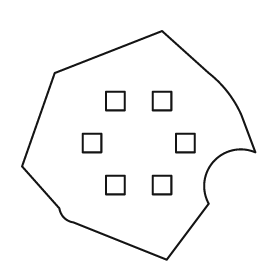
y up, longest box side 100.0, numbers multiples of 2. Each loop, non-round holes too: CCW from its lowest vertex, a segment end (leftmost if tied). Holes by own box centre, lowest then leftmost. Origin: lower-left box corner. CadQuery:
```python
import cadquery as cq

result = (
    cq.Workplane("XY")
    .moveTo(62.0, 0.0)
    .lineTo(80.0, 24.0)
    .threePointArc((82.0, 42.0), (100.0, 46.0))
    .lineTo(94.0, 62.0)
    .threePointArc((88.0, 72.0), (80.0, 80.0))
    .lineTo(60.0, 98.0)
    .lineTo(14.0, 80.0)
    .lineTo(0.0, 40.0)
    .lineTo(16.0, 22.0)
    .threePointArc((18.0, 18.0), (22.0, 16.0))
    .close()
    .moveTo(36.0, 28.0)
    .lineTo(44.0, 28.0)
    .lineTo(44.0, 36.0)
    .lineTo(36.0, 36.0)
    .close()
    .moveTo(56.0, 28.0)
    .lineTo(64.0, 28.0)
    .lineTo(64.0, 36.0)
    .lineTo(56.0, 36.0)
    .close()
    .moveTo(26.0, 46.0)
    .lineTo(34.0, 46.0)
    .lineTo(34.0, 54.0)
    .lineTo(26.0, 54.0)
    .close()
    .moveTo(66.0, 46.0)
    .lineTo(74.0, 46.0)
    .lineTo(74.0, 54.0)
    .lineTo(66.0, 54.0)
    .close()
    .moveTo(36.0, 64.0)
    .lineTo(44.0, 64.0)
    .lineTo(44.0, 72.0)
    .lineTo(36.0, 72.0)
    .close()
    .moveTo(56.0, 64.0)
    .lineTo(64.0, 64.0)
    .lineTo(64.0, 72.0)
    .lineTo(56.0, 72.0)
    .close()
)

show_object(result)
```